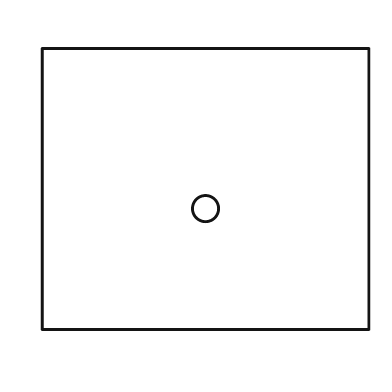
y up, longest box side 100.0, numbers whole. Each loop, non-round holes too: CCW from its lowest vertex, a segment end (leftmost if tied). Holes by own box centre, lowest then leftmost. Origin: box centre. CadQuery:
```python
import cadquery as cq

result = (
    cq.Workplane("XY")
    .moveTo(-50.0, -43.0)
    .lineTo(50.0, -43.0)
    .lineTo(50.0, 43.0)
    .lineTo(-50.0, 43.0)
    .close()
    .moveTo(0.0, -6.0)
    .circle(4.0)
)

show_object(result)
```